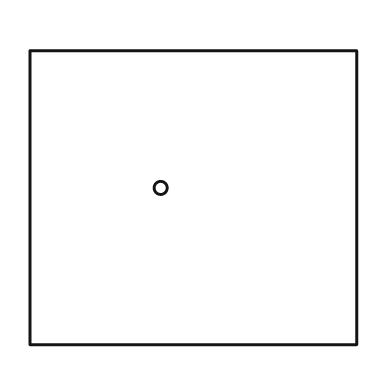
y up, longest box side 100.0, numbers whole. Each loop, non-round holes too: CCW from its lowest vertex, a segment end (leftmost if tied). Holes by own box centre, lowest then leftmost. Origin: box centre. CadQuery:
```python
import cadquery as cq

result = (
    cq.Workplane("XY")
    .moveTo(-50.0, -45.0)
    .lineTo(50.0, -45.0)
    .lineTo(50.0, 45.0)
    .lineTo(-50.0, 45.0)
    .close()
    .moveTo(-10.0, 3.0)
    .circle(2.0)
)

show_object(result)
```